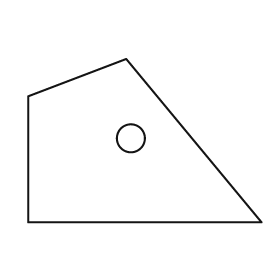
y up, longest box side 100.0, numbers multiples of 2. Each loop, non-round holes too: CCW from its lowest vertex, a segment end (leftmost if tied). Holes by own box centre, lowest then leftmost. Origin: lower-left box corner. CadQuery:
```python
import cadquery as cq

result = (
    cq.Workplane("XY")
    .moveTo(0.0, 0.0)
    .lineTo(100.0, 0.0)
    .lineTo(42.0, 70.0)
    .lineTo(0.0, 54.0)
    .close()
    .moveTo(44.0, 36.0)
    .circle(6.0)
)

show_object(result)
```